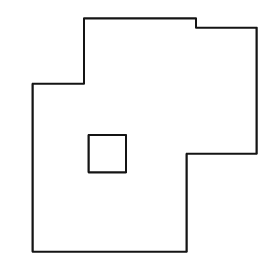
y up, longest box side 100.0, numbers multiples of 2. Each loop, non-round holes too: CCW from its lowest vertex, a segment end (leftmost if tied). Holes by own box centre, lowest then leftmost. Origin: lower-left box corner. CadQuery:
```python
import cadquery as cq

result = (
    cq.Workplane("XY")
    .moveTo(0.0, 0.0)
    .lineTo(66.0, 0.0)
    .lineTo(66.0, 42.0)
    .lineTo(96.0, 42.0)
    .lineTo(96.0, 96.0)
    .lineTo(70.0, 96.0)
    .lineTo(70.0, 100.0)
    .lineTo(22.0, 100.0)
    .lineTo(22.0, 72.0)
    .lineTo(0.0, 72.0)
    .close()
    .moveTo(24.0, 34.0)
    .lineTo(40.0, 34.0)
    .lineTo(40.0, 50.0)
    .lineTo(24.0, 50.0)
    .close()
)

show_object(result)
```